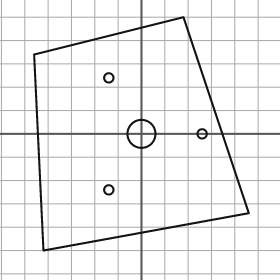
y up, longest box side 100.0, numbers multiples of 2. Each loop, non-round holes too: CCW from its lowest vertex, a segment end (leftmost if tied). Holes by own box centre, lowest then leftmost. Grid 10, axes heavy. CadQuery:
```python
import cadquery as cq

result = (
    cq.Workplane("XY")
    .moveTo(-42.0, -50.0)
    .lineTo(46.0, -34.0)
    .lineTo(18.0, 50.0)
    .lineTo(-46.0, 34.0)
    .close()
    .moveTo(-14.0, -24.0)
    .circle(2.0)
    .moveTo(0.0, 0.0)
    .circle(6.0)
    .moveTo(26.0, 0.0)
    .circle(2.0)
    .moveTo(-14.0, 24.0)
    .circle(2.0)
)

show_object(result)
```